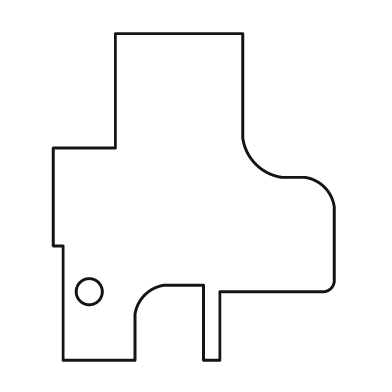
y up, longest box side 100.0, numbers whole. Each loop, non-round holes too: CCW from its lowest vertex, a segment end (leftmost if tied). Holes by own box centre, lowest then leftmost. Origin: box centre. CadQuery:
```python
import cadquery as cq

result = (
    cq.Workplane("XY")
    .moveTo(-40.0, -50.0)
    .lineTo(-18.0, -50.0)
    .lineTo(-18.0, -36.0)
    .threePointArc((-15.0, -30.0), (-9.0, -27.0))
    .lineTo(3.0, -27.0)
    .lineTo(3.0, -50.0)
    .lineTo(8.0, -50.0)
    .lineTo(8.0, -29.0)
    .lineTo(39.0, -29.0)
    .threePointArc((42.0, -28.0), (43.0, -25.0))
    .lineTo(43.0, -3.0)
    .threePointArc((40.0, 3.0), (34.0, 6.0))
    .lineTo(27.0, 6.0)
    .threePointArc((19.0, 10.0), (15.0, 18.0))
    .lineTo(15.0, 50.0)
    .lineTo(-24.0, 50.0)
    .lineTo(-24.0, 15.0)
    .lineTo(-43.0, 15.0)
    .lineTo(-43.0, -15.0)
    .lineTo(-40.0, -15.0)
    .close()
    .moveTo(-32.0, -29.0)
    .circle(4.0)
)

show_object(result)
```